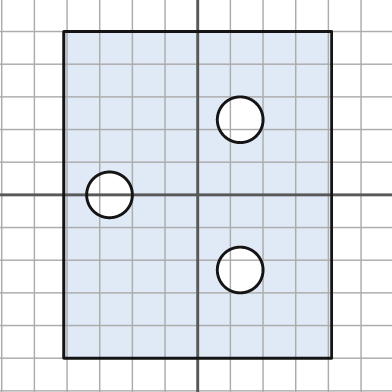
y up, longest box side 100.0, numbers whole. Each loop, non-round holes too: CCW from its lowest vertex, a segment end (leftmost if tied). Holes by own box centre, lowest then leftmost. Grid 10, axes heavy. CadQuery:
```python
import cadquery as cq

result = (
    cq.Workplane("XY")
    .moveTo(-41.0, -50.0)
    .lineTo(41.0, -50.0)
    .lineTo(41.0, 50.0)
    .lineTo(-41.0, 50.0)
    .close()
    .moveTo(13.0, -23.0)
    .circle(7.0)
    .moveTo(-27.0, 0.0)
    .circle(7.0)
    .moveTo(13.0, 23.0)
    .circle(7.0)
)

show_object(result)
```